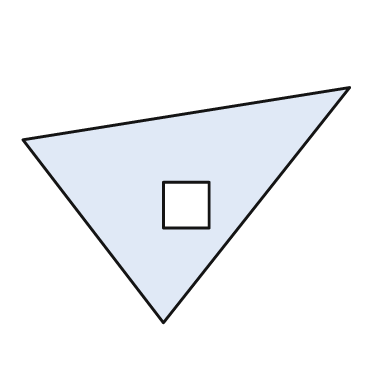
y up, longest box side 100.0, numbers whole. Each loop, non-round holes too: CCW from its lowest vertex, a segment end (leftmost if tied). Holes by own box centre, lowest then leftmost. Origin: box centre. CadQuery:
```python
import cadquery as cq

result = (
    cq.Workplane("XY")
    .moveTo(-7.0, -36.0)
    .lineTo(50.0, 36.0)
    .lineTo(-50.0, 20.0)
    .close()
    .moveTo(-7.0, -7.0)
    .lineTo(7.0, -7.0)
    .lineTo(7.0, 7.0)
    .lineTo(-7.0, 7.0)
    .close()
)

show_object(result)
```